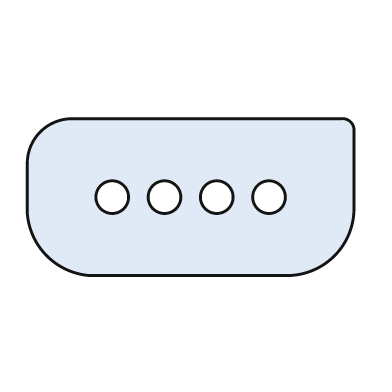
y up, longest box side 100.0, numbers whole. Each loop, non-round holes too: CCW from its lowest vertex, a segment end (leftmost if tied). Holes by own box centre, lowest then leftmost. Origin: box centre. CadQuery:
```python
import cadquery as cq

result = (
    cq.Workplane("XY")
    .moveTo(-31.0, -24.0)
    .lineTo(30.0, -24.0)
    .threePointArc((44.0, -18.0), (50.0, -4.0))
    .lineTo(50.0, 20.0)
    .threePointArc((49.0, 23.0), (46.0, 24.0))
    .lineTo(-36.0, 24.0)
    .threePointArc((-46.0, 20.0), (-50.0, 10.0))
    .lineTo(-50.0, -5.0)
    .threePointArc((-44.0, -18.0), (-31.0, -24.0))
    .close()
    .moveTo(-24.0, 0.0)
    .circle(5.0)
    .moveTo(-8.0, 0.0)
    .circle(5.0)
    .moveTo(8.0, 0.0)
    .circle(5.0)
    .moveTo(24.0, 0.0)
    .circle(5.0)
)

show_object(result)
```